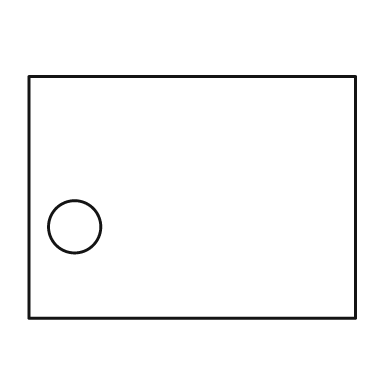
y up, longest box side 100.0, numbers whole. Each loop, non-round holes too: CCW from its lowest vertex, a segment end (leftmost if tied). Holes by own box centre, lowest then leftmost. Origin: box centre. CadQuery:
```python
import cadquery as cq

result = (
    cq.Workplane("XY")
    .moveTo(-50.0, -37.0)
    .lineTo(50.0, -37.0)
    .lineTo(50.0, 37.0)
    .lineTo(-50.0, 37.0)
    .close()
    .moveTo(-36.0, -9.0)
    .circle(8.0)
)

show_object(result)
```